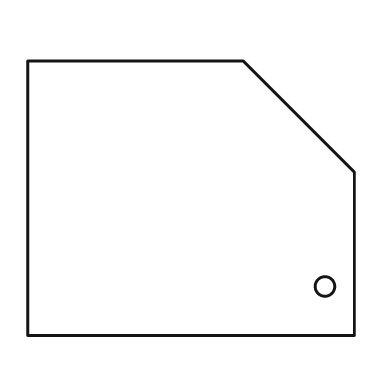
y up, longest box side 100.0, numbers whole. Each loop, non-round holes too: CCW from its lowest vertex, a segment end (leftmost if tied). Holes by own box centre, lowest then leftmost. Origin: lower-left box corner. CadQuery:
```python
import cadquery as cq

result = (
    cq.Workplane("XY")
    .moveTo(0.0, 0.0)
    .lineTo(100.0, 0.0)
    .lineTo(100.0, 50.0)
    .lineTo(66.0, 84.0)
    .lineTo(0.0, 84.0)
    .close()
    .moveTo(91.0, 15.0)
    .circle(3.0)
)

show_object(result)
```